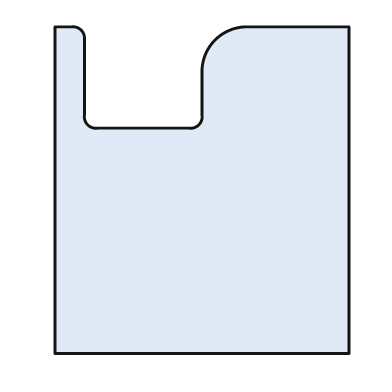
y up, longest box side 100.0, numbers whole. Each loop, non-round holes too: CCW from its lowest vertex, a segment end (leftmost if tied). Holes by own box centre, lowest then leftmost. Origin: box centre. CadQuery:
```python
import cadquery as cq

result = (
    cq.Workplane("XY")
    .moveTo(-45.0, -50.0)
    .lineTo(45.0, -50.0)
    .lineTo(45.0, 50.0)
    .lineTo(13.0, 50.0)
    .threePointArc((4.0, 46.0), (0.0, 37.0))
    .lineTo(0.0, 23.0)
    .threePointArc((-1.0, 20.0), (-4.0, 19.0))
    .lineTo(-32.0, 19.0)
    .threePointArc((-35.0, 20.0), (-36.0, 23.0))
    .lineTo(-36.0, 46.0)
    .threePointArc((-37.0, 49.0), (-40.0, 50.0))
    .lineTo(-45.0, 50.0)
    .close()
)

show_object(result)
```